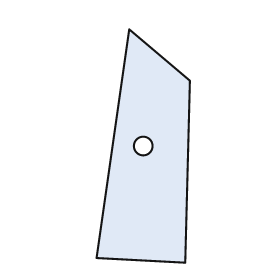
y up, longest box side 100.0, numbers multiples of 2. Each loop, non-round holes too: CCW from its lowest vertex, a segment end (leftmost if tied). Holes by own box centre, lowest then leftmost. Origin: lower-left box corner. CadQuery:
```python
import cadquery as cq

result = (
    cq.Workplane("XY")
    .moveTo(38.0, 0.0)
    .lineTo(40.0, 78.0)
    .lineTo(14.0, 100.0)
    .lineTo(0.0, 2.0)
    .close()
    .moveTo(20.0, 50.0)
    .circle(4.0)
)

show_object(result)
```